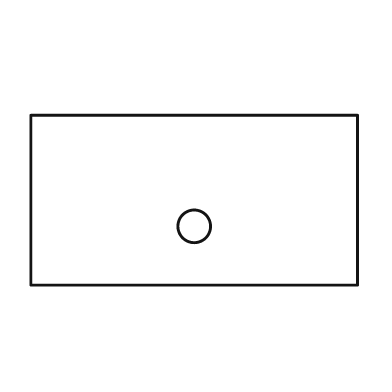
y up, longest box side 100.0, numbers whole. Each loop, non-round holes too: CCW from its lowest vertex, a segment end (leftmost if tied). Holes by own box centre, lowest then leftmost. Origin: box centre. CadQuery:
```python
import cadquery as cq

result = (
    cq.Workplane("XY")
    .moveTo(-50.0, -26.0)
    .lineTo(50.0, -26.0)
    .lineTo(50.0, 26.0)
    .lineTo(-50.0, 26.0)
    .close()
    .moveTo(0.0, -8.0)
    .circle(5.0)
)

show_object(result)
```